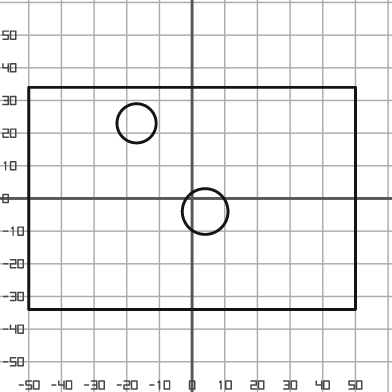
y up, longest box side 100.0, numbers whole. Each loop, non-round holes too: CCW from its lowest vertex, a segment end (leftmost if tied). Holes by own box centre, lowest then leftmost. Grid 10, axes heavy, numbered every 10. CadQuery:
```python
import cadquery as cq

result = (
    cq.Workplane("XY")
    .moveTo(-50.0, -34.0)
    .lineTo(50.0, -34.0)
    .lineTo(50.0, 34.0)
    .lineTo(-50.0, 34.0)
    .close()
    .moveTo(4.0, -4.0)
    .circle(7.0)
    .moveTo(-17.0, 23.0)
    .circle(6.0)
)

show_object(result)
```